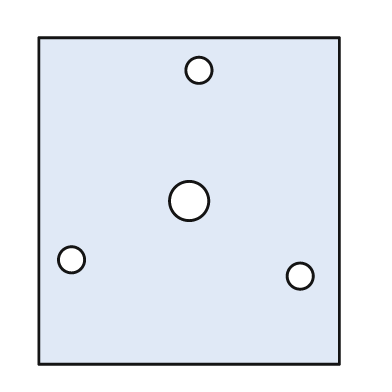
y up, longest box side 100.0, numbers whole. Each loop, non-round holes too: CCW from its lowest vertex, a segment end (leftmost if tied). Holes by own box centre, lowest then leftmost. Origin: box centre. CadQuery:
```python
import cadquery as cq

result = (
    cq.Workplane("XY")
    .moveTo(-46.0, -50.0)
    .lineTo(46.0, -50.0)
    .lineTo(46.0, 50.0)
    .lineTo(-46.0, 50.0)
    .close()
    .moveTo(34.0, -23.0)
    .circle(4.0)
    .moveTo(-36.0, -18.0)
    .circle(4.0)
    .moveTo(0.0, 0.0)
    .circle(6.0)
    .moveTo(3.0, 40.0)
    .circle(4.0)
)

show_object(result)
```